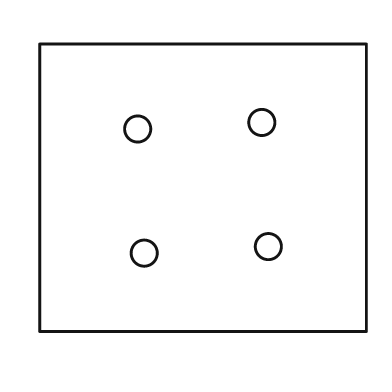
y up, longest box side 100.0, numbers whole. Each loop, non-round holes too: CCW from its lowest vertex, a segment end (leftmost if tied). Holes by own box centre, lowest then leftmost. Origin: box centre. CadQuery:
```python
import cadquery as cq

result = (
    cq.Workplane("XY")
    .moveTo(-50.0, -44.0)
    .lineTo(50.0, -44.0)
    .lineTo(50.0, 44.0)
    .lineTo(-50.0, 44.0)
    .close()
    .moveTo(-18.0, -20.0)
    .circle(4.0)
    .moveTo(20.0, -18.0)
    .circle(4.0)
    .moveTo(-20.0, 18.0)
    .circle(4.0)
    .moveTo(18.0, 20.0)
    .circle(4.0)
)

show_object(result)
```